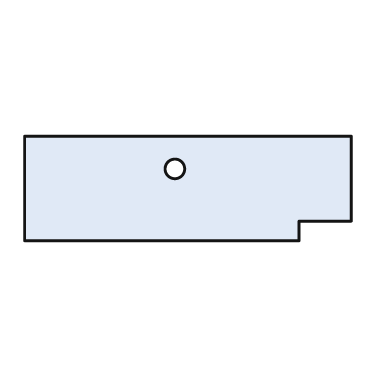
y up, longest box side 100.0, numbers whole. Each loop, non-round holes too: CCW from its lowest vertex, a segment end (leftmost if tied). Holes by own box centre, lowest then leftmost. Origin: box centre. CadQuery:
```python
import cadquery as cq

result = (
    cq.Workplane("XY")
    .moveTo(-50.0, -16.0)
    .lineTo(34.0, -16.0)
    .lineTo(34.0, -10.0)
    .lineTo(50.0, -10.0)
    .lineTo(50.0, 16.0)
    .lineTo(-50.0, 16.0)
    .close()
    .moveTo(-4.0, 6.0)
    .circle(3.0)
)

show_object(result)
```